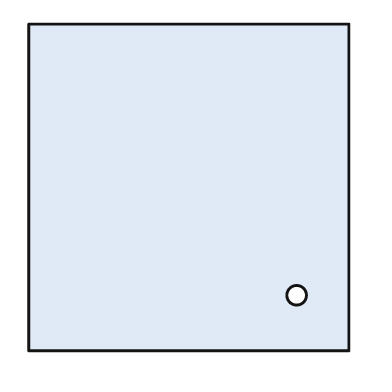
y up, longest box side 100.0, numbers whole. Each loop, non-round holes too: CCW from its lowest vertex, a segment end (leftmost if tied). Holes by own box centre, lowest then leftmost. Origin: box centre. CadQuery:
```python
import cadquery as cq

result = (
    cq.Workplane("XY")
    .moveTo(-49.0, -50.0)
    .lineTo(49.0, -50.0)
    .lineTo(49.0, 50.0)
    .lineTo(-49.0, 50.0)
    .close()
    .moveTo(33.0, -33.0)
    .circle(3.0)
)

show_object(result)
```